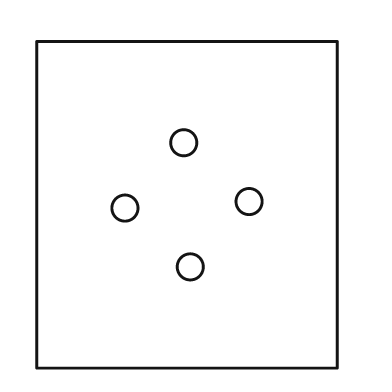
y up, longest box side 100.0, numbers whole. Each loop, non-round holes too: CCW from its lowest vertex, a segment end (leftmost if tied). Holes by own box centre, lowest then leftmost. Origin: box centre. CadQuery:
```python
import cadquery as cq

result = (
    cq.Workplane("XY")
    .moveTo(-46.0, -50.0)
    .lineTo(46.0, -50.0)
    .lineTo(46.0, 50.0)
    .lineTo(-46.0, 50.0)
    .close()
    .moveTo(1.0, -19.0)
    .circle(4.0)
    .moveTo(-19.0, -1.0)
    .circle(4.0)
    .moveTo(19.0, 1.0)
    .circle(4.0)
    .moveTo(-1.0, 19.0)
    .circle(4.0)
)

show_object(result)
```